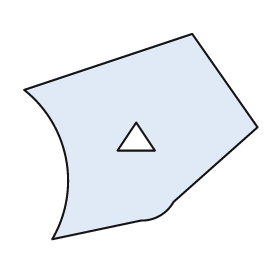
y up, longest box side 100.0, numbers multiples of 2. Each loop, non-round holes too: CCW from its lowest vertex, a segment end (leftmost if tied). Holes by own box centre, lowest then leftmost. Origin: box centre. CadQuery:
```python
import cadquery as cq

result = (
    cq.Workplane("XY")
    .moveTo(-38.0, -44.0)
    .lineTo(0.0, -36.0)
    .threePointArc((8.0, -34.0), (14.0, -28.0))
    .lineTo(50.0, 4.0)
    .lineTo(22.0, 44.0)
    .lineTo(-50.0, 20.0)
    .threePointArc((-32.0, -10.0), (-38.0, -44.0))
    .close()
    .moveTo(-10.0, -6.0)
    .lineTo(6.0, -6.0)
    .lineTo(-2.0, 6.0)
    .close()
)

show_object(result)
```